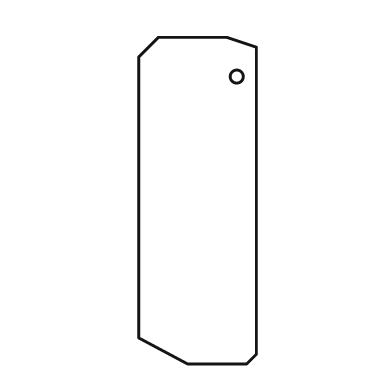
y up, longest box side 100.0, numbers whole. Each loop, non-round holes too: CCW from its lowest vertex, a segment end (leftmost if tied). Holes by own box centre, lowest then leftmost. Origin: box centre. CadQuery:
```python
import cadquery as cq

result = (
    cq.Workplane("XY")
    .moveTo(-3.0, -50.0)
    .lineTo(15.0, -50.0)
    .lineTo(18.0, -47.0)
    .lineTo(18.0, 47.0)
    .lineTo(9.0, 50.0)
    .lineTo(-12.0, 50.0)
    .lineTo(-18.0, 44.0)
    .lineTo(-18.0, -42.0)
    .close()
    .moveTo(12.0, 38.0)
    .circle(2.0)
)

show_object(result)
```